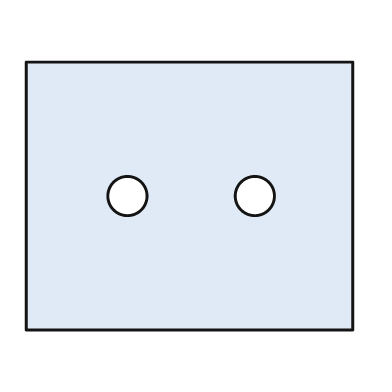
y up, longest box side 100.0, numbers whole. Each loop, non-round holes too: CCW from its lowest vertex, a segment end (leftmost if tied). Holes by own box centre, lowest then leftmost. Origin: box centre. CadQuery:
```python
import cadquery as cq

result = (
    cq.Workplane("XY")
    .moveTo(-50.0, -41.0)
    .lineTo(50.0, -41.0)
    .lineTo(50.0, 41.0)
    .lineTo(-50.0, 41.0)
    .close()
    .moveTo(-19.0, 0.0)
    .circle(6.0)
    .moveTo(20.0, 0.0)
    .circle(6.0)
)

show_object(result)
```